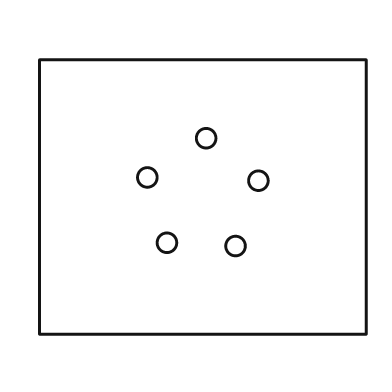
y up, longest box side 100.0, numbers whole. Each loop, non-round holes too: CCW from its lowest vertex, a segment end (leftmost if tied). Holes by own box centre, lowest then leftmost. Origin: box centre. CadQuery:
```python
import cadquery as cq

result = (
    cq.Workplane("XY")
    .moveTo(-50.0, -42.0)
    .lineTo(50.0, -42.0)
    .lineTo(50.0, 42.0)
    .lineTo(-50.0, 42.0)
    .close()
    .moveTo(10.0, -15.0)
    .circle(3.0)
    .moveTo(-11.0, -14.0)
    .circle(3.0)
    .moveTo(17.0, 5.0)
    .circle(3.0)
    .moveTo(-17.0, 6.0)
    .circle(3.0)
    .moveTo(1.0, 18.0)
    .circle(3.0)
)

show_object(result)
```